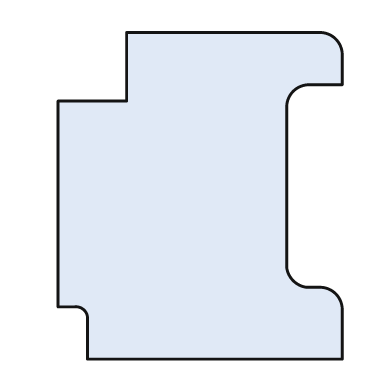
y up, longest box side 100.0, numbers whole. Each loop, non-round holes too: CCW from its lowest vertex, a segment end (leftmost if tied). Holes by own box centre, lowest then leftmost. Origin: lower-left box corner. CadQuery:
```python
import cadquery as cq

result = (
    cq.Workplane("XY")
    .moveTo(9.0, 0.0)
    .lineTo(87.0, 0.0)
    .lineTo(87.0, 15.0)
    .threePointArc((85.0, 20.0), (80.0, 22.0))
    .lineTo(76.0, 22.0)
    .threePointArc((72.0, 24.0), (70.0, 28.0))
    .lineTo(70.0, 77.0)
    .threePointArc((72.0, 82.0), (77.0, 84.0))
    .lineTo(87.0, 84.0)
    .lineTo(87.0, 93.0)
    .threePointArc((85.0, 98.0), (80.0, 100.0))
    .lineTo(21.0, 100.0)
    .lineTo(21.0, 79.0)
    .lineTo(0.0, 79.0)
    .lineTo(0.0, 16.0)
    .lineTo(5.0, 16.0)
    .threePointArc((8.0, 15.0), (9.0, 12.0))
    .close()
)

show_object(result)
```